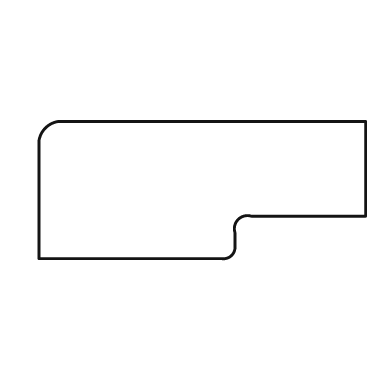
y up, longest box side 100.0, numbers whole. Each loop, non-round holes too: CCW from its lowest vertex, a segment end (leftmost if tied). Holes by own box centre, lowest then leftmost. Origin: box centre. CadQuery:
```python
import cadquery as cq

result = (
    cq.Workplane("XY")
    .moveTo(-50.0, -21.0)
    .lineTo(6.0, -21.0)
    .threePointArc((9.0, -20.0), (10.0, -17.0))
    .lineTo(10.0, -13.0)
    .threePointArc((11.0, -9.0), (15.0, -8.0))
    .lineTo(50.0, -8.0)
    .lineTo(50.0, 21.0)
    .lineTo(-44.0, 21.0)
    .threePointArc((-48.0, 19.0), (-50.0, 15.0))
    .close()
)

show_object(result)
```